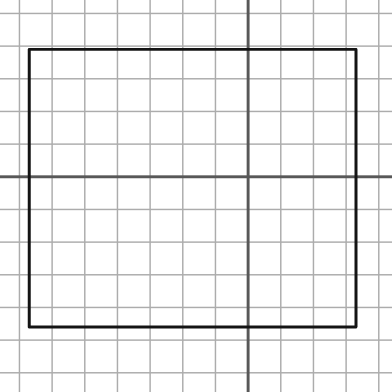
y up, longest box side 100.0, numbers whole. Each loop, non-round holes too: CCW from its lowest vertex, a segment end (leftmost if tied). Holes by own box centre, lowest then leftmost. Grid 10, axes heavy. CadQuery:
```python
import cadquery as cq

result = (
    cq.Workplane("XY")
    .moveTo(-67.0, -46.0)
    .lineTo(33.0, -46.0)
    .lineTo(33.0, 39.0)
    .lineTo(-67.0, 39.0)
    .close()
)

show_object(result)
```